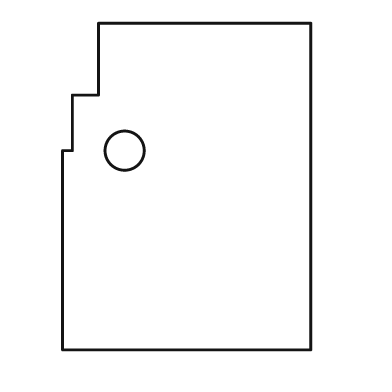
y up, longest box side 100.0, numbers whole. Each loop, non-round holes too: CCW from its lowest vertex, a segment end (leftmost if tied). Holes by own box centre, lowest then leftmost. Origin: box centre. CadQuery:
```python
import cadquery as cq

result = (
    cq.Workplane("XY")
    .moveTo(-38.0, -50.0)
    .lineTo(38.0, -50.0)
    .lineTo(38.0, 50.0)
    .lineTo(-27.0, 50.0)
    .lineTo(-27.0, 28.0)
    .lineTo(-35.0, 28.0)
    .lineTo(-35.0, 11.0)
    .lineTo(-38.0, 11.0)
    .close()
    .moveTo(-19.0, 11.0)
    .circle(6.0)
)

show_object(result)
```